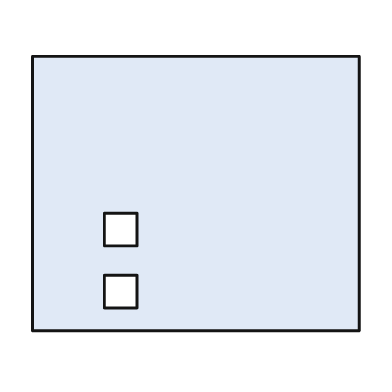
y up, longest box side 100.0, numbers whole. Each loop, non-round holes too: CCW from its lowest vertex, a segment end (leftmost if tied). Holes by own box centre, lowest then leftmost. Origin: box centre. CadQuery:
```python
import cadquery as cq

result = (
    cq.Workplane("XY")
    .moveTo(-50.0, -42.0)
    .lineTo(50.0, -42.0)
    .lineTo(50.0, 42.0)
    .lineTo(-50.0, 42.0)
    .close()
    .moveTo(-28.0, -35.0)
    .lineTo(-18.0, -35.0)
    .lineTo(-18.0, -25.0)
    .lineTo(-28.0, -25.0)
    .close()
    .moveTo(-28.0, -16.0)
    .lineTo(-18.0, -16.0)
    .lineTo(-18.0, -6.0)
    .lineTo(-28.0, -6.0)
    .close()
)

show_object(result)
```